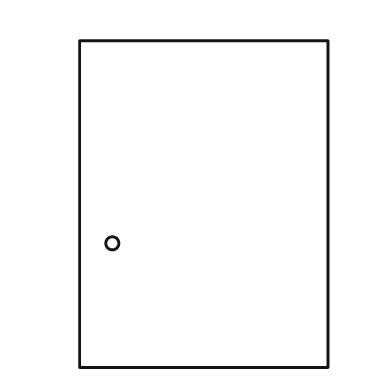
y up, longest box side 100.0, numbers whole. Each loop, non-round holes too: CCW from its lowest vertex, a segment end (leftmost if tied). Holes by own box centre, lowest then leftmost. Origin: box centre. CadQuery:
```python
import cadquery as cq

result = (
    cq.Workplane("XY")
    .moveTo(-38.0, -50.0)
    .lineTo(38.0, -50.0)
    .lineTo(38.0, 50.0)
    .lineTo(-38.0, 50.0)
    .close()
    .moveTo(-28.0, -12.0)
    .circle(2.0)
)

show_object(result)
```